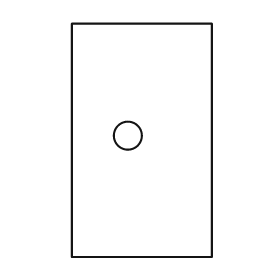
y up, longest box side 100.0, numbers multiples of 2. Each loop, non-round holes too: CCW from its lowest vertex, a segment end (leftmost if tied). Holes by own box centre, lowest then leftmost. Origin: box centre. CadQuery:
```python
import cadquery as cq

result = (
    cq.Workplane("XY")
    .moveTo(-30.0, -50.0)
    .lineTo(30.0, -50.0)
    .lineTo(30.0, 50.0)
    .lineTo(-30.0, 50.0)
    .close()
    .moveTo(-6.0, 2.0)
    .circle(6.0)
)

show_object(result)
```